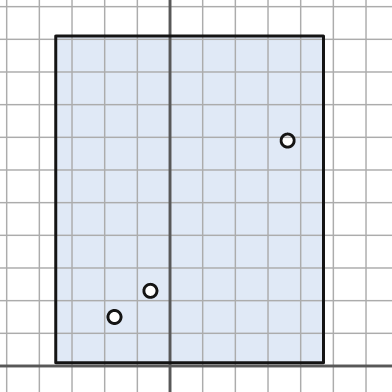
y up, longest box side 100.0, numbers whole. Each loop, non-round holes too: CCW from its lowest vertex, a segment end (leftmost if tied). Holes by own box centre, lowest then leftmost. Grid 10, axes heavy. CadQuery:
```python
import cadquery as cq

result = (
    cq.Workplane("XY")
    .moveTo(-35.0, 1.0)
    .lineTo(47.0, 1.0)
    .lineTo(47.0, 101.0)
    .lineTo(-35.0, 101.0)
    .close()
    .moveTo(-17.0, 15.0)
    .circle(2.0)
    .moveTo(-6.0, 23.0)
    .circle(2.0)
    .moveTo(36.0, 69.0)
    .circle(2.0)
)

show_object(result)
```